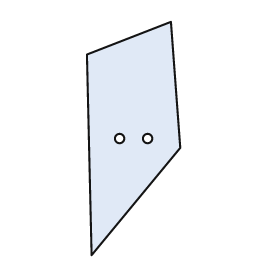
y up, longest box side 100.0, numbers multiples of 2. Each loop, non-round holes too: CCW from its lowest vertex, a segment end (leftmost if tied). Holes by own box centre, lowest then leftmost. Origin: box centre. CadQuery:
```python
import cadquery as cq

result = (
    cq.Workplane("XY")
    .moveTo(-18.0, -50.0)
    .lineTo(20.0, -4.0)
    .lineTo(16.0, 50.0)
    .lineTo(-20.0, 36.0)
    .close()
    .moveTo(-6.0, 0.0)
    .circle(2.0)
    .moveTo(6.0, 0.0)
    .circle(2.0)
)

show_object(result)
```